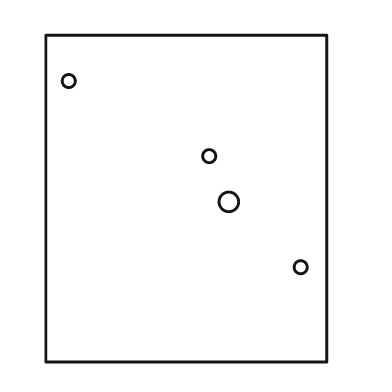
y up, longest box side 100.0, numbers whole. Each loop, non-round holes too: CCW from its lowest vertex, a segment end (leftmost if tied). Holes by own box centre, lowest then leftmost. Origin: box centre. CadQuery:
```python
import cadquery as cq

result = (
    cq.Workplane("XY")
    .moveTo(-43.0, -50.0)
    .lineTo(43.0, -50.0)
    .lineTo(43.0, 50.0)
    .lineTo(-43.0, 50.0)
    .close()
    .moveTo(35.0, -21.0)
    .circle(2.0)
    .moveTo(13.0, -1.0)
    .circle(3.0)
    .moveTo(7.0, 13.0)
    .circle(2.0)
    .moveTo(-36.0, 36.0)
    .circle(2.0)
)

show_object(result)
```